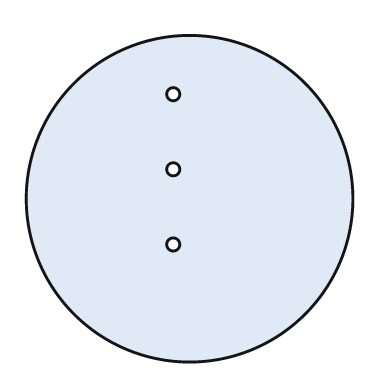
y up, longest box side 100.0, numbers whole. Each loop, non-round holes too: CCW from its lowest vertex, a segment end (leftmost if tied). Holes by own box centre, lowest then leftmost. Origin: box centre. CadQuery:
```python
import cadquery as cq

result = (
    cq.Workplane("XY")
    .moveTo(0.0, 0.0)
    .circle(50.0)
    .moveTo(-5.0, -14.0)
    .circle(2.0)
    .moveTo(-5.0, 9.0)
    .circle(2.0)
    .moveTo(-5.0, 32.0)
    .circle(2.0)
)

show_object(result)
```